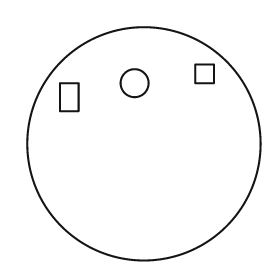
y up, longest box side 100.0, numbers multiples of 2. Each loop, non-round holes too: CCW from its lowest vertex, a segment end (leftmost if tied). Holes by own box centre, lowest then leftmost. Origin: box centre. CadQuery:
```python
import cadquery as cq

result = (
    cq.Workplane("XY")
    .moveTo(0.0, 0.0)
    .circle(50.0)
    .moveTo(-36.0, 14.0)
    .lineTo(-28.0, 14.0)
    .lineTo(-28.0, 26.0)
    .lineTo(-36.0, 26.0)
    .close()
    .moveTo(-4.0, 26.0)
    .circle(6.0)
    .moveTo(22.0, 26.0)
    .lineTo(30.0, 26.0)
    .lineTo(30.0, 34.0)
    .lineTo(22.0, 34.0)
    .close()
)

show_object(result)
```